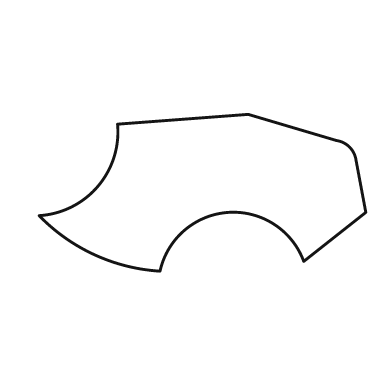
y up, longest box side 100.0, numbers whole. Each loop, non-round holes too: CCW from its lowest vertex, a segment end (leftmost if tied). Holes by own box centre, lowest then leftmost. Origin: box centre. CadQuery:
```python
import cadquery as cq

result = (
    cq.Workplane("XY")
    .moveTo(-13.0, -24.0)
    .threePointArc((8.0, -6.0), (31.0, -21.0))
    .lineTo(50.0, -6.0)
    .lineTo(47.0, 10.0)
    .threePointArc((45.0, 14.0), (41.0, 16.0))
    .lineTo(14.0, 24.0)
    .lineTo(-26.0, 21.0)
    .threePointArc((-32.0, 2.0), (-50.0, -7.0))
    .threePointArc((-33.0, -19.0), (-13.0, -24.0))
    .close()
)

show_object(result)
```